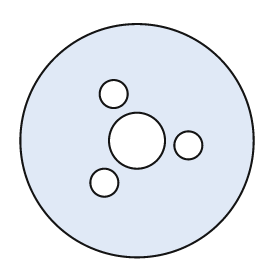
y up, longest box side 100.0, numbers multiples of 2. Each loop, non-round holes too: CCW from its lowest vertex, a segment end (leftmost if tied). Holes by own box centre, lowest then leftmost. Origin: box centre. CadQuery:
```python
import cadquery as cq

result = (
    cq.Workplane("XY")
    .moveTo(0.0, 0.0)
    .circle(50.0)
    .moveTo(-14.0, -18.0)
    .circle(6.0)
    .moveTo(22.0, -2.0)
    .circle(6.0)
    .moveTo(0.0, 0.0)
    .circle(12.0)
    .moveTo(-10.0, 20.0)
    .circle(6.0)
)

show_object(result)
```